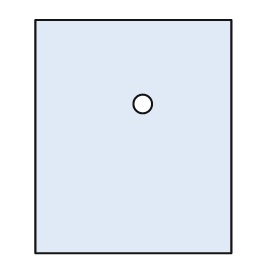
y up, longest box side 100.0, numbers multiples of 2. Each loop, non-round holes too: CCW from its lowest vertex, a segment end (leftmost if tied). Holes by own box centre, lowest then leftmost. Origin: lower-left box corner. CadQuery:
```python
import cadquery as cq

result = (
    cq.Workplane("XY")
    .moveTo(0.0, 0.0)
    .lineTo(84.0, 0.0)
    .lineTo(84.0, 100.0)
    .lineTo(0.0, 100.0)
    .close()
    .moveTo(46.0, 64.0)
    .circle(4.0)
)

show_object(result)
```